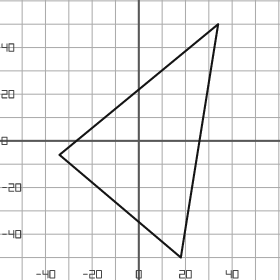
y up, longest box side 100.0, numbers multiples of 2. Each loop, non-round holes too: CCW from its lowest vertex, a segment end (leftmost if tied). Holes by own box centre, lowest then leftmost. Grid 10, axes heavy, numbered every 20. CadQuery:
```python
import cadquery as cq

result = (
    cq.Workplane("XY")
    .moveTo(18.0, -50.0)
    .lineTo(34.0, 50.0)
    .lineTo(-34.0, -6.0)
    .close()
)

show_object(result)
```